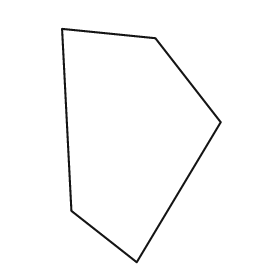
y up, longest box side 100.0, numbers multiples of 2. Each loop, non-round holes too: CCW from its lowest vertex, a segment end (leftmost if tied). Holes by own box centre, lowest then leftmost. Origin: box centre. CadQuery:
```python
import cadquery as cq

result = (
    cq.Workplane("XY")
    .moveTo(-2.0, -50.0)
    .lineTo(34.0, 10.0)
    .lineTo(6.0, 46.0)
    .lineTo(-34.0, 50.0)
    .lineTo(-30.0, -28.0)
    .close()
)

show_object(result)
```